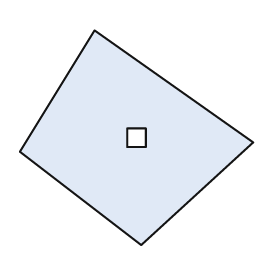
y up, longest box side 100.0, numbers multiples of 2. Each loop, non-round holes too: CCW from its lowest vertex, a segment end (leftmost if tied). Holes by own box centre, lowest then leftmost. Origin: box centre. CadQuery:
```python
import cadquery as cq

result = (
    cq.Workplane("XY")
    .moveTo(2.0, -46.0)
    .lineTo(50.0, -2.0)
    .lineTo(-18.0, 46.0)
    .lineTo(-50.0, -6.0)
    .close()
    .moveTo(-4.0, -4.0)
    .lineTo(4.0, -4.0)
    .lineTo(4.0, 4.0)
    .lineTo(-4.0, 4.0)
    .close()
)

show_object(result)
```